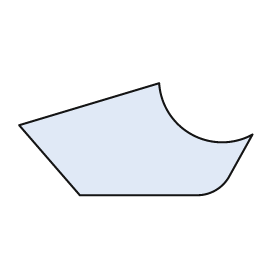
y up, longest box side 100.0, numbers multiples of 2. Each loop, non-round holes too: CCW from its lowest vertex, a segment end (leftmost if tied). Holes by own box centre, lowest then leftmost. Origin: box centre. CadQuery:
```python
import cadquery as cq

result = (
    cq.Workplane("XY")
    .moveTo(-24.0, -24.0)
    .lineTo(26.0, -24.0)
    .threePointArc((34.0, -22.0), (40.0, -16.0))
    .lineTo(50.0, 2.0)
    .threePointArc((24.0, 2.0), (10.0, 24.0))
    .lineTo(-50.0, 6.0)
    .close()
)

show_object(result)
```